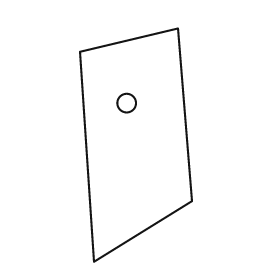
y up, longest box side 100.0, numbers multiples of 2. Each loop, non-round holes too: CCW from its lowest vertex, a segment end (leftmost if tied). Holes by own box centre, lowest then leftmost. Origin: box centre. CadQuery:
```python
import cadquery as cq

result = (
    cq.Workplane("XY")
    .moveTo(-18.0, -50.0)
    .lineTo(24.0, -24.0)
    .lineTo(18.0, 50.0)
    .lineTo(-24.0, 40.0)
    .close()
    .moveTo(-4.0, 18.0)
    .circle(4.0)
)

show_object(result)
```